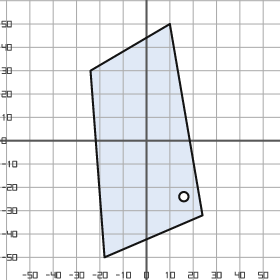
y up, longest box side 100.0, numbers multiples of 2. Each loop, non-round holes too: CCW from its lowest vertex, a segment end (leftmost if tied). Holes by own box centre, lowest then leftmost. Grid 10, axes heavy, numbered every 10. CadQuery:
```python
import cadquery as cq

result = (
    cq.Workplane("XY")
    .moveTo(-18.0, -50.0)
    .lineTo(24.0, -32.0)
    .lineTo(10.0, 50.0)
    .lineTo(-24.0, 30.0)
    .close()
    .moveTo(16.0, -24.0)
    .circle(2.0)
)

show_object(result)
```